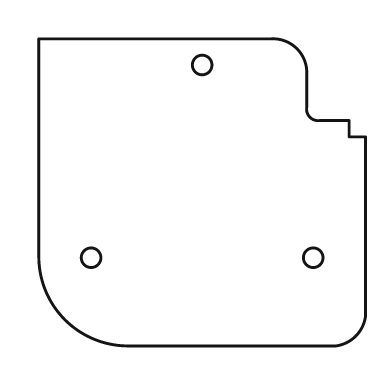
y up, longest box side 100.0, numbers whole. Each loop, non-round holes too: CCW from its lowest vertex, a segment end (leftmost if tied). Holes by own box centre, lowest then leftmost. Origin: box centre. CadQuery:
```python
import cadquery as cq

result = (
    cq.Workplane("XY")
    .moveTo(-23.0, -47.0)
    .lineTo(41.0, -47.0)
    .threePointArc((47.0, -44.0), (50.0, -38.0))
    .lineTo(50.0, 17.0)
    .lineTo(45.0, 17.0)
    .lineTo(45.0, 22.0)
    .lineTo(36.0, 22.0)
    .threePointArc((33.0, 23.0), (32.0, 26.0))
    .lineTo(32.0, 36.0)
    .threePointArc((29.0, 44.0), (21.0, 47.0))
    .lineTo(-50.0, 47.0)
    .lineTo(-50.0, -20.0)
    .threePointArc((-42.0, -39.0), (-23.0, -47.0))
    .close()
    .moveTo(-34.0, -20.0)
    .circle(3.0)
    .moveTo(34.0, -20.0)
    .circle(3.0)
    .moveTo(0.0, 39.0)
    .circle(3.0)
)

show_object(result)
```